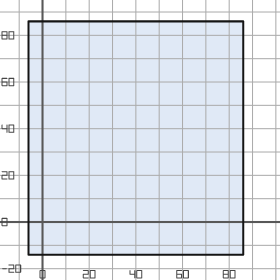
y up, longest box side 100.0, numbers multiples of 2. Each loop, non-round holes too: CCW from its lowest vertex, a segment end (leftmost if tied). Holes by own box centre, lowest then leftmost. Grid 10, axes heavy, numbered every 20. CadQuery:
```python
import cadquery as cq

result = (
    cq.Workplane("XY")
    .moveTo(-6.0, -14.0)
    .lineTo(86.0, -14.0)
    .lineTo(86.0, 86.0)
    .lineTo(-6.0, 86.0)
    .close()
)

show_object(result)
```